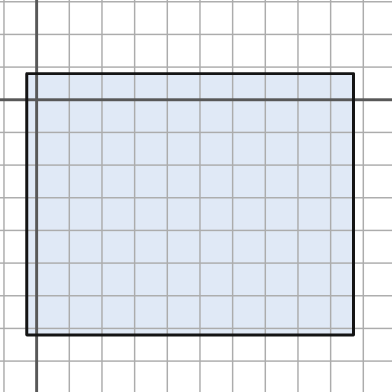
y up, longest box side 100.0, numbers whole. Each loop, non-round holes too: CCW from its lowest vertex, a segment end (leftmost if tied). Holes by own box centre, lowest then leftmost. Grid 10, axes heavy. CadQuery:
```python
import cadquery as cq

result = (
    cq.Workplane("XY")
    .moveTo(-3.0, -72.0)
    .lineTo(97.0, -72.0)
    .lineTo(97.0, 8.0)
    .lineTo(-3.0, 8.0)
    .close()
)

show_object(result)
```